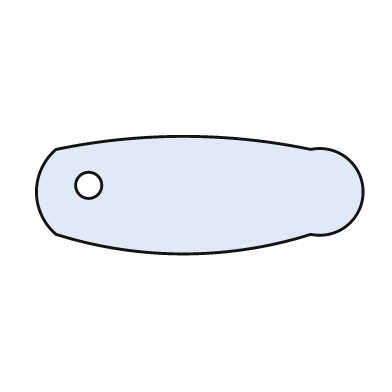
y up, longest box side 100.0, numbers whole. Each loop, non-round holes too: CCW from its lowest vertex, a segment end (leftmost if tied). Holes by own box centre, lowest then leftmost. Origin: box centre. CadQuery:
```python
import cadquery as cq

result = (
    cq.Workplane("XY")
    .moveTo(-44.0, -12.0)
    .threePointArc((-5.0, -18.0), (34.0, -12.0))
    .threePointArc((50.0, 1.0), (34.0, 14.0))
    .threePointArc((-5.0, 18.0), (-44.0, 14.0))
    .threePointArc((-50.0, 1.0), (-44.0, -12.0))
    .close()
    .moveTo(-34.0, 3.0)
    .circle(4.0)
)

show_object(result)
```